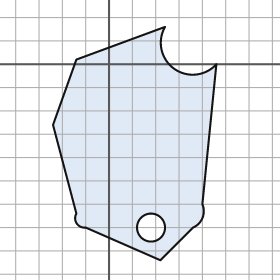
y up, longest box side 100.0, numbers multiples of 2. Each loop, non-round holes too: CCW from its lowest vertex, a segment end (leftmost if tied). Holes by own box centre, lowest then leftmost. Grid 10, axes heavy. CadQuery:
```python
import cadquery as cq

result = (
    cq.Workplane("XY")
    .moveTo(22.0, -84.0)
    .lineTo(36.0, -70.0)
    .threePointArc((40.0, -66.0), (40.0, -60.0))
    .lineTo(46.0, 0.0)
    .threePointArc((28.0, -2.0), (24.0, 16.0))
    .lineTo(-14.0, 2.0)
    .lineTo(-24.0, -26.0)
    .lineTo(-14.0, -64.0)
    .threePointArc((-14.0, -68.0), (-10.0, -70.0))
    .close()
    .moveTo(18.0, -70.0)
    .circle(6.0)
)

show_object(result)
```